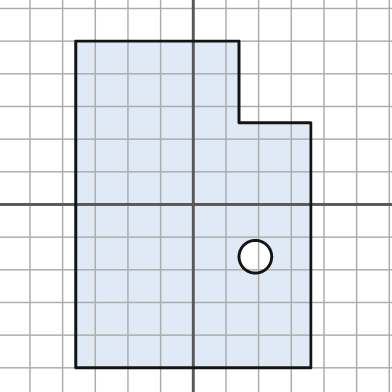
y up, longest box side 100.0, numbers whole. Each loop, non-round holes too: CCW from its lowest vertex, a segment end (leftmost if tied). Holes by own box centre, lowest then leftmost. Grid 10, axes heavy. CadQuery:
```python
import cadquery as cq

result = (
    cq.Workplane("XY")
    .moveTo(-36.0, -50.0)
    .lineTo(36.0, -50.0)
    .lineTo(36.0, 25.0)
    .lineTo(14.0, 25.0)
    .lineTo(14.0, 50.0)
    .lineTo(-36.0, 50.0)
    .close()
    .moveTo(19.0, -16.0)
    .circle(5.0)
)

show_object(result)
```